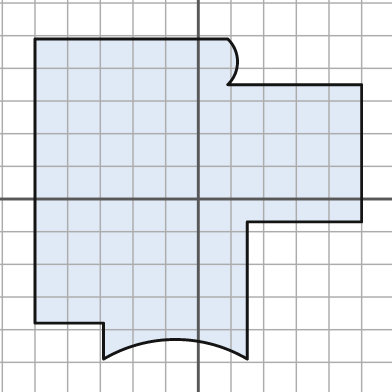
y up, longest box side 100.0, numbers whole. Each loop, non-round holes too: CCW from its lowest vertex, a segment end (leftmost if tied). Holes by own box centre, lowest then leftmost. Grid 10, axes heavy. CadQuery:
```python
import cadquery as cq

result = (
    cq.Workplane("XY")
    .moveTo(-29.0, -49.0)
    .threePointArc((-7.0, -43.0), (15.0, -49.0))
    .lineTo(15.0, -7.0)
    .lineTo(50.0, -7.0)
    .lineTo(50.0, 35.0)
    .lineTo(9.0, 35.0)
    .threePointArc((12.0, 42.0), (9.0, 49.0))
    .lineTo(-50.0, 49.0)
    .lineTo(-50.0, -38.0)
    .lineTo(-29.0, -38.0)
    .close()
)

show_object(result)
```